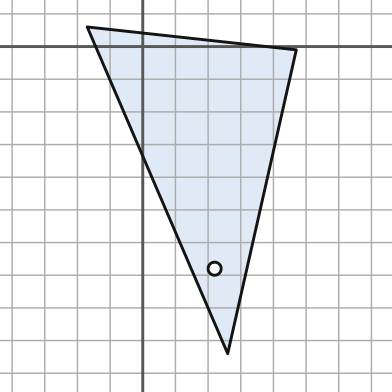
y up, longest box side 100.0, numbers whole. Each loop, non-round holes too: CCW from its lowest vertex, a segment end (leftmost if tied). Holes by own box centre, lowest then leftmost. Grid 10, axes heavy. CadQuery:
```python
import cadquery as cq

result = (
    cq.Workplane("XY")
    .moveTo(26.0, -94.0)
    .lineTo(47.0, -1.0)
    .lineTo(-17.0, 6.0)
    .close()
    .moveTo(22.0, -68.0)
    .circle(2.0)
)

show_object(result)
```